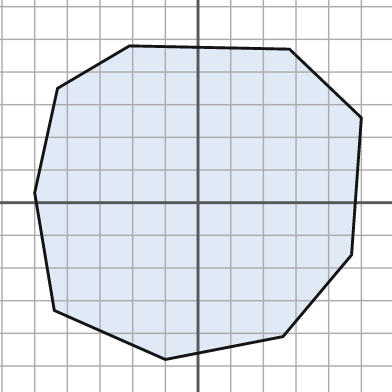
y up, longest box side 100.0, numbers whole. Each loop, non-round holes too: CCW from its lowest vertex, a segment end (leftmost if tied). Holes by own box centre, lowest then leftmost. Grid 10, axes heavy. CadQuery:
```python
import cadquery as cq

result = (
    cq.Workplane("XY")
    .moveTo(-10.0, -48.0)
    .lineTo(26.0, -41.0)
    .lineTo(47.0, -16.0)
    .lineTo(50.0, 26.0)
    .lineTo(28.0, 47.0)
    .lineTo(-21.0, 48.0)
    .lineTo(-43.0, 35.0)
    .lineTo(-50.0, 3.0)
    .lineTo(-44.0, -33.0)
    .close()
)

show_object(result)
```